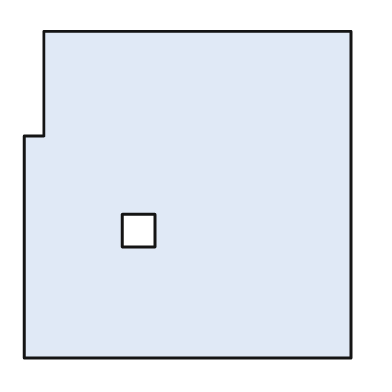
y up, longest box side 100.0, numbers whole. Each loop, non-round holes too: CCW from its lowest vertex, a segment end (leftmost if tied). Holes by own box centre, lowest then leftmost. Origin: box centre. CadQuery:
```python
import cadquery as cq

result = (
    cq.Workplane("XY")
    .moveTo(-50.0, -50.0)
    .lineTo(50.0, -50.0)
    .lineTo(50.0, 50.0)
    .lineTo(-44.0, 50.0)
    .lineTo(-44.0, 18.0)
    .lineTo(-50.0, 18.0)
    .close()
    .moveTo(-20.0, -16.0)
    .lineTo(-10.0, -16.0)
    .lineTo(-10.0, -6.0)
    .lineTo(-20.0, -6.0)
    .close()
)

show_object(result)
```